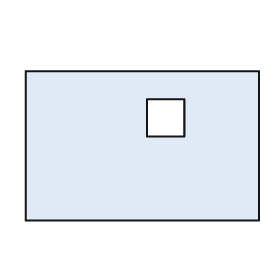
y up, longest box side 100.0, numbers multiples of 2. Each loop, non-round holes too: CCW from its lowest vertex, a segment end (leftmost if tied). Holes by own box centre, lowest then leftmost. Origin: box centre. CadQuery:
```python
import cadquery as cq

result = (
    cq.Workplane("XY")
    .moveTo(-50.0, -32.0)
    .lineTo(50.0, -32.0)
    .lineTo(50.0, 32.0)
    .lineTo(-50.0, 32.0)
    .close()
    .moveTo(2.0, 4.0)
    .lineTo(18.0, 4.0)
    .lineTo(18.0, 20.0)
    .lineTo(2.0, 20.0)
    .close()
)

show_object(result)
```